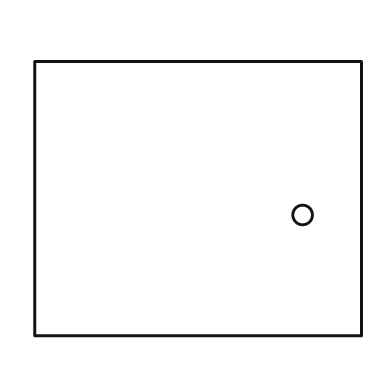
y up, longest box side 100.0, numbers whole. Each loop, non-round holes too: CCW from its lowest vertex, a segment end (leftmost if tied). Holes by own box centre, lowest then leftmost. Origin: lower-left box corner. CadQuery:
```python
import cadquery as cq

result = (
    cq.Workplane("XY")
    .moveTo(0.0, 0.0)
    .lineTo(100.0, 0.0)
    .lineTo(100.0, 84.0)
    .lineTo(0.0, 84.0)
    .close()
    .moveTo(82.0, 37.0)
    .circle(3.0)
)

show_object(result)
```